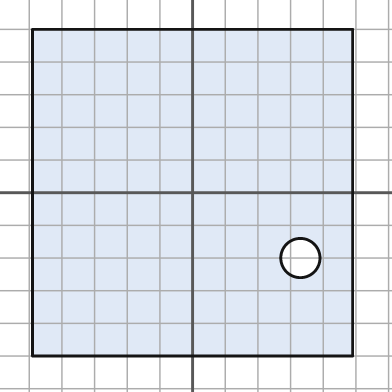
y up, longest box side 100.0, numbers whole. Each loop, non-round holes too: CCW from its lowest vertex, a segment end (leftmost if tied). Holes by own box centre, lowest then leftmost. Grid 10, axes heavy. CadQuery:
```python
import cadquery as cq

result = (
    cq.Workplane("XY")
    .moveTo(-49.0, -50.0)
    .lineTo(49.0, -50.0)
    .lineTo(49.0, 50.0)
    .lineTo(-49.0, 50.0)
    .close()
    .moveTo(33.0, -20.0)
    .circle(6.0)
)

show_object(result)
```